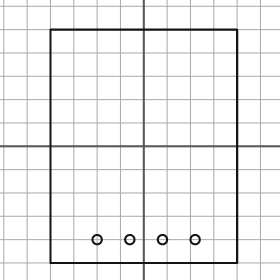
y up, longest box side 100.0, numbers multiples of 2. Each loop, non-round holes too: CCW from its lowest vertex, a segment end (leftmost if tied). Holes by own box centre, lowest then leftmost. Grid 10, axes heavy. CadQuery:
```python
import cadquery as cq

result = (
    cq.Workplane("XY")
    .moveTo(-40.0, -50.0)
    .lineTo(40.0, -50.0)
    .lineTo(40.0, 50.0)
    .lineTo(-40.0, 50.0)
    .close()
    .moveTo(-20.0, -40.0)
    .circle(2.0)
    .moveTo(-6.0, -40.0)
    .circle(2.0)
    .moveTo(8.0, -40.0)
    .circle(2.0)
    .moveTo(22.0, -40.0)
    .circle(2.0)
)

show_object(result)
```